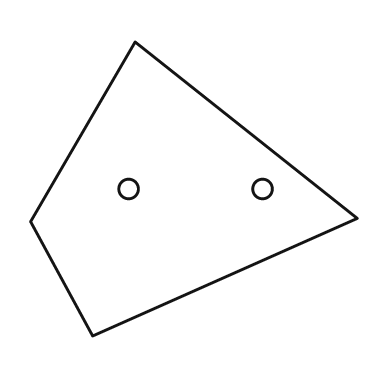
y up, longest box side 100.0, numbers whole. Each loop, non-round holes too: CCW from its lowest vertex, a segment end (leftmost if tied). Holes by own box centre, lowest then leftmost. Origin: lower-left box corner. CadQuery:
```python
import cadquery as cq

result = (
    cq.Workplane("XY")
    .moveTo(19.0, 0.0)
    .lineTo(100.0, 36.0)
    .lineTo(32.0, 90.0)
    .lineTo(0.0, 35.0)
    .close()
    .moveTo(30.0, 45.0)
    .circle(3.0)
    .moveTo(71.0, 45.0)
    .circle(3.0)
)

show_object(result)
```